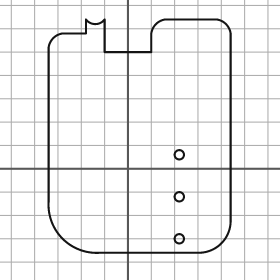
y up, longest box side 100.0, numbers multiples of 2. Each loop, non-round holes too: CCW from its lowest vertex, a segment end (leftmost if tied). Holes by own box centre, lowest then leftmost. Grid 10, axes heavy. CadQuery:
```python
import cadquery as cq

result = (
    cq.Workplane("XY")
    .moveTo(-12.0, -36.0)
    .lineTo(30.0, -36.0)
    .threePointArc((40.0, -32.0), (44.0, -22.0))
    .lineTo(44.0, 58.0)
    .threePointArc((42.0, 62.0), (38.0, 64.0))
    .lineTo(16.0, 64.0)
    .threePointArc((12.0, 62.0), (10.0, 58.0))
    .lineTo(10.0, 50.0)
    .lineTo(-10.0, 50.0)
    .lineTo(-10.0, 64.0)
    .threePointArc((-14.0, 62.0), (-18.0, 64.0))
    .lineTo(-18.0, 58.0)
    .lineTo(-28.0, 58.0)
    .threePointArc((-32.0, 56.0), (-34.0, 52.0))
    .lineTo(-34.0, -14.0)
    .threePointArc((-28.0, -30.0), (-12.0, -36.0))
    .close()
    .moveTo(22.0, -30.0)
    .circle(2.0)
    .moveTo(22.0, -12.0)
    .circle(2.0)
    .moveTo(22.0, 6.0)
    .circle(2.0)
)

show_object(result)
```